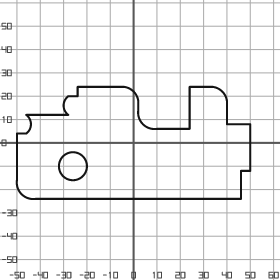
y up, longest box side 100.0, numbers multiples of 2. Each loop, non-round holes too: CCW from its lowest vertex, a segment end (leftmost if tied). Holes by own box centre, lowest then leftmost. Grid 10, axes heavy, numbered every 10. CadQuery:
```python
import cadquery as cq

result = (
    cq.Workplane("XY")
    .moveTo(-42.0, -24.0)
    .lineTo(46.0, -24.0)
    .lineTo(46.0, -12.0)
    .lineTo(50.0, -12.0)
    .lineTo(50.0, 8.0)
    .lineTo(40.0, 8.0)
    .lineTo(40.0, 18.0)
    .threePointArc((38.0, 22.0), (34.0, 24.0))
    .lineTo(24.0, 24.0)
    .lineTo(24.0, 6.0)
    .lineTo(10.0, 6.0)
    .threePointArc((4.0, 8.0), (2.0, 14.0))
    .lineTo(2.0, 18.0)
    .threePointArc((0.0, 22.0), (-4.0, 24.0))
    .lineTo(-24.0, 24.0)
    .lineTo(-24.0, 20.0)
    .lineTo(-28.0, 20.0)
    .threePointArc((-30.0, 16.0), (-28.0, 12.0))
    .lineTo(-46.0, 12.0)
    .threePointArc((-44.0, 8.0), (-46.0, 4.0))
    .lineTo(-50.0, 4.0)
    .lineTo(-50.0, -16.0)
    .threePointArc((-48.0, -22.0), (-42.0, -24.0))
    .close()
    .moveTo(-26.0, -10.0)
    .circle(6.0)
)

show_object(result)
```